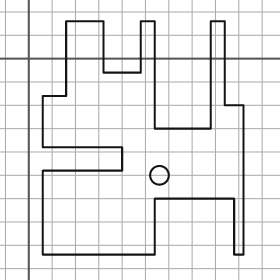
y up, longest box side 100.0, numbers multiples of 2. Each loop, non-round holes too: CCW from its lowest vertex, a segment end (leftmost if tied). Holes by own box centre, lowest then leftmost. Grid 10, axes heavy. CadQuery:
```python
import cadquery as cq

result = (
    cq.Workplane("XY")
    .moveTo(6.0, -84.0)
    .lineTo(54.0, -84.0)
    .lineTo(54.0, -60.0)
    .lineTo(88.0, -60.0)
    .lineTo(88.0, -84.0)
    .lineTo(92.0, -84.0)
    .lineTo(92.0, -20.0)
    .lineTo(84.0, -20.0)
    .lineTo(84.0, 16.0)
    .lineTo(78.0, 16.0)
    .lineTo(78.0, -30.0)
    .lineTo(54.0, -30.0)
    .lineTo(54.0, 16.0)
    .lineTo(48.0, 16.0)
    .lineTo(48.0, -6.0)
    .lineTo(32.0, -6.0)
    .lineTo(32.0, 16.0)
    .lineTo(16.0, 16.0)
    .lineTo(16.0, -16.0)
    .lineTo(6.0, -16.0)
    .lineTo(6.0, -38.0)
    .lineTo(40.0, -38.0)
    .lineTo(40.0, -48.0)
    .lineTo(6.0, -48.0)
    .close()
    .moveTo(56.0, -50.0)
    .circle(4.0)
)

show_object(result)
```